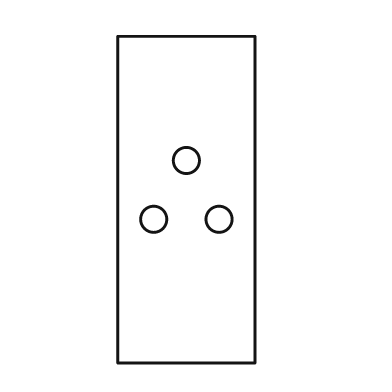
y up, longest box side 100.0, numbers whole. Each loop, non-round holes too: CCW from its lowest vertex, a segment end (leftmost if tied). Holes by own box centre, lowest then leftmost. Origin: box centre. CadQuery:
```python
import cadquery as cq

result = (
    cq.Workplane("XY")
    .moveTo(-21.0, -50.0)
    .lineTo(21.0, -50.0)
    .lineTo(21.0, 50.0)
    .lineTo(-21.0, 50.0)
    .close()
    .moveTo(-10.0, -6.0)
    .circle(4.0)
    .moveTo(10.0, -6.0)
    .circle(4.0)
    .moveTo(0.0, 12.0)
    .circle(4.0)
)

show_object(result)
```